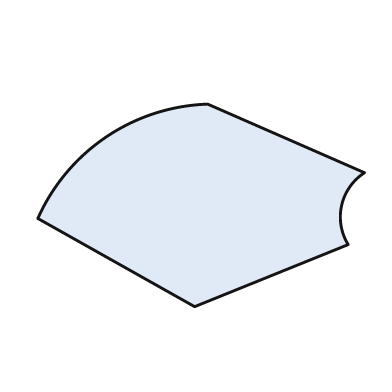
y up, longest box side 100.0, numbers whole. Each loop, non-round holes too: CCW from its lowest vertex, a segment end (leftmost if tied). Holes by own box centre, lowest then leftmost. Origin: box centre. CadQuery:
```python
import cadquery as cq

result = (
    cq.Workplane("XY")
    .moveTo(-2.0, -31.0)
    .lineTo(45.0, -12.0)
    .threePointArc((43.0, 0.0), (50.0, 10.0))
    .lineTo(2.0, 31.0)
    .threePointArc((-29.0, 21.0), (-50.0, -4.0))
    .close()
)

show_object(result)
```